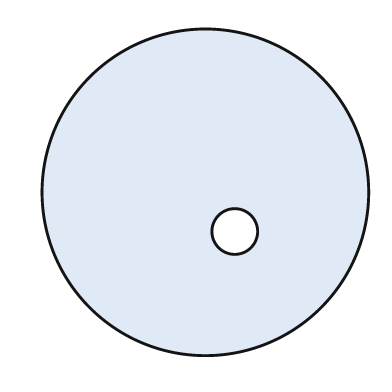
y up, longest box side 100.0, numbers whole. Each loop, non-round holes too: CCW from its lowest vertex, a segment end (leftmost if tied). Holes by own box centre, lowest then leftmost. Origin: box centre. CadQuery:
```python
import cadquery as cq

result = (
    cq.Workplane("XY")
    .moveTo(0.0, 0.0)
    .circle(50.0)
    .moveTo(9.0, -12.0)
    .circle(7.0)
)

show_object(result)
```